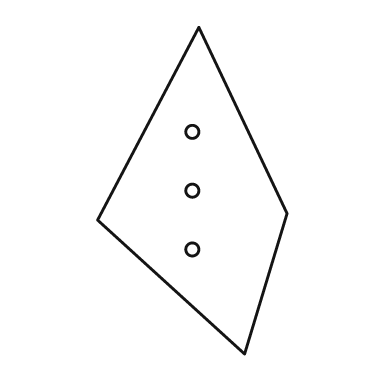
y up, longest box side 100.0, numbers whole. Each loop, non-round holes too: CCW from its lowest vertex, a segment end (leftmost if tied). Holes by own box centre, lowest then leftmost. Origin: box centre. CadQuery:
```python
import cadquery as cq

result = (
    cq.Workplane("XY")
    .moveTo(16.0, -50.0)
    .lineTo(29.0, -7.0)
    .lineTo(2.0, 50.0)
    .lineTo(-29.0, -9.0)
    .close()
    .moveTo(0.0, -18.0)
    .circle(2.0)
    .moveTo(0.0, 0.0)
    .circle(2.0)
    .moveTo(0.0, 18.0)
    .circle(2.0)
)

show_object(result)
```